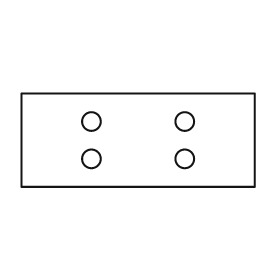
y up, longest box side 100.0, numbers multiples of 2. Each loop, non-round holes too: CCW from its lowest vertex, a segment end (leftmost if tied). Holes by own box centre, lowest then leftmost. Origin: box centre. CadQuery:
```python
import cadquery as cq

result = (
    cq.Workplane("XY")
    .moveTo(-50.0, -20.0)
    .lineTo(50.0, -20.0)
    .lineTo(50.0, 20.0)
    .lineTo(-50.0, 20.0)
    .close()
    .moveTo(-20.0, -8.0)
    .circle(4.0)
    .moveTo(20.0, -8.0)
    .circle(4.0)
    .moveTo(-20.0, 8.0)
    .circle(4.0)
    .moveTo(20.0, 8.0)
    .circle(4.0)
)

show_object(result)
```